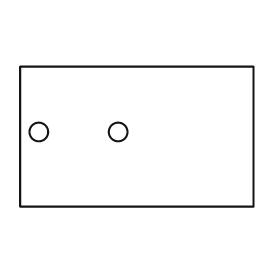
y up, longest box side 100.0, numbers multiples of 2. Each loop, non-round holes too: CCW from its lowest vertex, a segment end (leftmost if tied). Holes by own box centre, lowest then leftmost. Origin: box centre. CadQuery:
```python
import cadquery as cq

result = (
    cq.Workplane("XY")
    .moveTo(-50.0, -30.0)
    .lineTo(50.0, -30.0)
    .lineTo(50.0, 30.0)
    .lineTo(-50.0, 30.0)
    .close()
    .moveTo(-42.0, 2.0)
    .circle(4.0)
    .moveTo(-8.0, 2.0)
    .circle(4.0)
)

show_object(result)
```